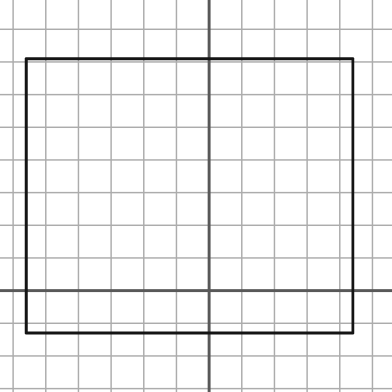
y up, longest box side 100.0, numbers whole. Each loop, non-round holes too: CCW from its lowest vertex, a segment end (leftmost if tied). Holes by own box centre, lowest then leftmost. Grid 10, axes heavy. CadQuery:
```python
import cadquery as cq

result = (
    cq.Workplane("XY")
    .moveTo(-56.0, -13.0)
    .lineTo(44.0, -13.0)
    .lineTo(44.0, 71.0)
    .lineTo(-56.0, 71.0)
    .close()
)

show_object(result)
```